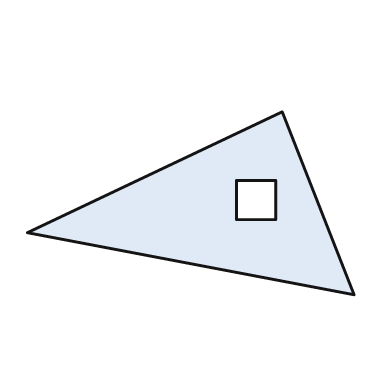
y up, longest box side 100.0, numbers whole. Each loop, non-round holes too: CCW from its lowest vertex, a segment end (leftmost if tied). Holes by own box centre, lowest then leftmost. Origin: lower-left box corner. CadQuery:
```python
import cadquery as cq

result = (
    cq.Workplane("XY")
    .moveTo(100.0, 0.0)
    .lineTo(78.0, 56.0)
    .lineTo(0.0, 19.0)
    .close()
    .moveTo(64.0, 23.0)
    .lineTo(76.0, 23.0)
    .lineTo(76.0, 35.0)
    .lineTo(64.0, 35.0)
    .close()
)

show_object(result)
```